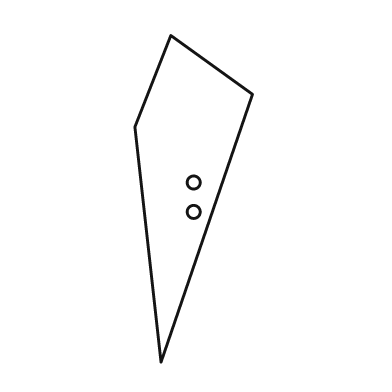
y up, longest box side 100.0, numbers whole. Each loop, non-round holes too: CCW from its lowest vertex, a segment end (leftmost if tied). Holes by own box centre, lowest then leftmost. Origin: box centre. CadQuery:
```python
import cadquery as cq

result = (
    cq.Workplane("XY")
    .moveTo(-10.0, -50.0)
    .lineTo(18.0, 32.0)
    .lineTo(-7.0, 50.0)
    .lineTo(-18.0, 22.0)
    .close()
    .moveTo(0.0, -4.0)
    .circle(2.0)
    .moveTo(0.0, 5.0)
    .circle(2.0)
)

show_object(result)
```